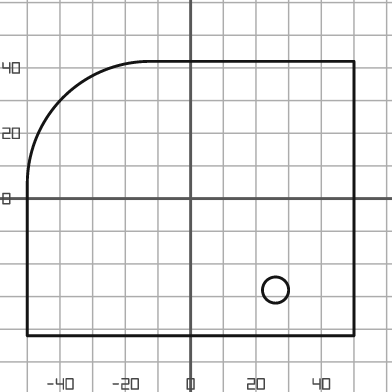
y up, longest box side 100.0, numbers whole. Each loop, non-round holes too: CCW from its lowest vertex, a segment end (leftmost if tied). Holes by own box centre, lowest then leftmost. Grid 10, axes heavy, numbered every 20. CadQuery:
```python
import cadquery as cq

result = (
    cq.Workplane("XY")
    .moveTo(-50.0, -42.0)
    .lineTo(50.0, -42.0)
    .lineTo(50.0, 42.0)
    .lineTo(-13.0, 42.0)
    .threePointArc((-39.0, 31.0), (-50.0, 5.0))
    .close()
    .moveTo(26.0, -28.0)
    .circle(4.0)
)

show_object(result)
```